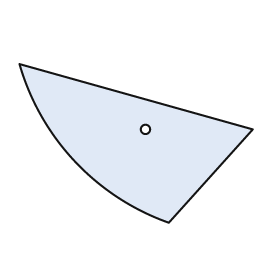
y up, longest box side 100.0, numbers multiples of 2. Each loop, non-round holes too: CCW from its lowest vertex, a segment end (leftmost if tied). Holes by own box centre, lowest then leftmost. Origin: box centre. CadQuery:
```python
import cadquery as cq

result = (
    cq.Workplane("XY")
    .moveTo(14.0, -34.0)
    .lineTo(50.0, 6.0)
    .lineTo(-50.0, 34.0)
    .threePointArc((-26.0, -8.0), (14.0, -34.0))
    .close()
    .moveTo(4.0, 6.0)
    .circle(2.0)
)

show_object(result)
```